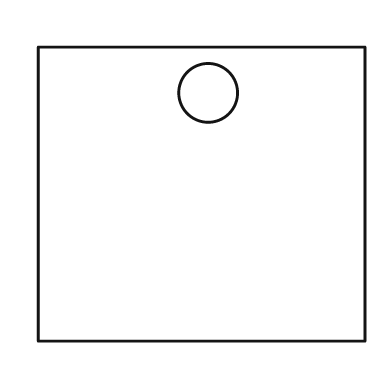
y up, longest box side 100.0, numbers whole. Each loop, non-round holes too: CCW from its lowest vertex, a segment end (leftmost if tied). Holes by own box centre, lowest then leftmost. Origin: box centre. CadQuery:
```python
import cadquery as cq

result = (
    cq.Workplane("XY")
    .moveTo(-50.0, -45.0)
    .lineTo(50.0, -45.0)
    .lineTo(50.0, 45.0)
    .lineTo(-50.0, 45.0)
    .close()
    .moveTo(2.0, 31.0)
    .circle(9.0)
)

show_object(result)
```